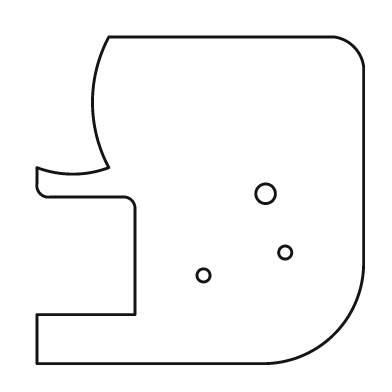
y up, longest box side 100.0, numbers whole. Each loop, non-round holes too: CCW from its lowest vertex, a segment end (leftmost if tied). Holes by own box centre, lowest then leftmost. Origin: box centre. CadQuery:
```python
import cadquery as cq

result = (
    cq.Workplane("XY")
    .moveTo(-50.0, -50.0)
    .lineTo(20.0, -50.0)
    .threePointArc((41.0, -41.0), (50.0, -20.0))
    .lineTo(50.0, 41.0)
    .threePointArc((47.0, 47.0), (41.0, 50.0))
    .lineTo(-28.0, 50.0)
    .threePointArc((-33.0, 30.0), (-28.0, 10.0))
    .threePointArc((-39.0, 8.0), (-50.0, 10.0))
    .lineTo(-50.0, 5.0)
    .threePointArc((-49.0, 2.0), (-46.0, 1.0))
    .lineTo(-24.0, 1.0)
    .threePointArc((-21.0, 0.0), (-20.0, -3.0))
    .lineTo(-20.0, -35.0)
    .lineTo(-50.0, -35.0)
    .close()
    .moveTo(1.0, -23.0)
    .circle(2.0)
    .moveTo(26.0, -16.0)
    .circle(2.0)
    .moveTo(20.0, 2.0)
    .circle(3.0)
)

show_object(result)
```